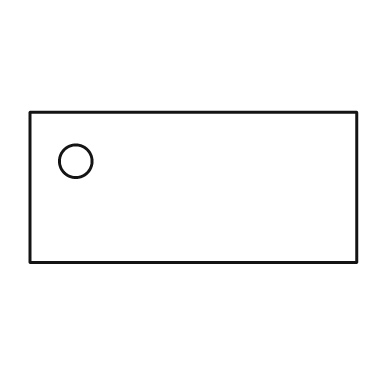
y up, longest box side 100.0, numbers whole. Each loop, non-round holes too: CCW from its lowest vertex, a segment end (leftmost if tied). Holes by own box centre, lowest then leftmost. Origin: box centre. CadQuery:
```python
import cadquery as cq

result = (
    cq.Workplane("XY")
    .moveTo(-50.0, -23.0)
    .lineTo(50.0, -23.0)
    .lineTo(50.0, 23.0)
    .lineTo(-50.0, 23.0)
    .close()
    .moveTo(-36.0, 8.0)
    .circle(5.0)
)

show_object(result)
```